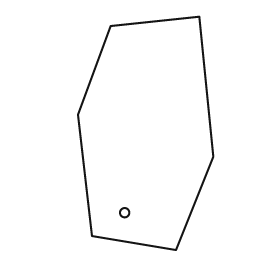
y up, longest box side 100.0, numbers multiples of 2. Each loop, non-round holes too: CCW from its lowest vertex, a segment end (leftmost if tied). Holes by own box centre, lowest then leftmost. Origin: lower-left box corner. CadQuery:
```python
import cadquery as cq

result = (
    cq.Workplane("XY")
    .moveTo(42.0, 0.0)
    .lineTo(58.0, 40.0)
    .lineTo(52.0, 100.0)
    .lineTo(14.0, 96.0)
    .lineTo(0.0, 58.0)
    .lineTo(6.0, 6.0)
    .close()
    .moveTo(20.0, 16.0)
    .circle(2.0)
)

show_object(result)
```